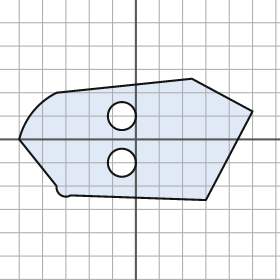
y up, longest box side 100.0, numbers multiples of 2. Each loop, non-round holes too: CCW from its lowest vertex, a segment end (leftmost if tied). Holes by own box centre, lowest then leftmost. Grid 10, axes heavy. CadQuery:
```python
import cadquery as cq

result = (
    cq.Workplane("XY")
    .moveTo(30.0, -26.0)
    .lineTo(50.0, 12.0)
    .lineTo(24.0, 26.0)
    .lineTo(-34.0, 20.0)
    .threePointArc((-44.0, 12.0), (-50.0, 0.0))
    .lineTo(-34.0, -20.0)
    .threePointArc((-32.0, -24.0), (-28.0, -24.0))
    .close()
    .moveTo(-6.0, -10.0)
    .circle(6.0)
    .moveTo(-6.0, 10.0)
    .circle(6.0)
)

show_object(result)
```